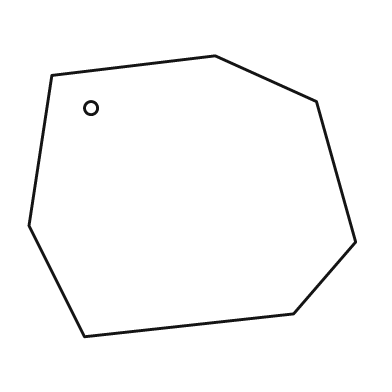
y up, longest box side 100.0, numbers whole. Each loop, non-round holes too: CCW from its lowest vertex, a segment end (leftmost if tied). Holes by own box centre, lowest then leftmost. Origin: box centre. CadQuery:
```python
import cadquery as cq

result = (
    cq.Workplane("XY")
    .moveTo(-33.0, -43.0)
    .lineTo(31.0, -36.0)
    .lineTo(50.0, -14.0)
    .lineTo(38.0, 29.0)
    .lineTo(7.0, 43.0)
    .lineTo(-43.0, 37.0)
    .lineTo(-50.0, -9.0)
    .close()
    .moveTo(-31.0, 27.0)
    .circle(2.0)
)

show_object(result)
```